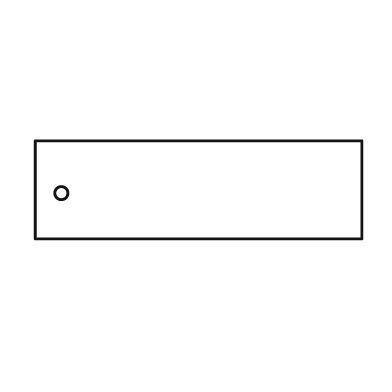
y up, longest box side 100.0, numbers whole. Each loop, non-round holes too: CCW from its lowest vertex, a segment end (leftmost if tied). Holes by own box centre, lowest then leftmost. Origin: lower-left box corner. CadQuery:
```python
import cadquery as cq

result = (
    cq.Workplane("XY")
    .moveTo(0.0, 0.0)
    .lineTo(100.0, 0.0)
    .lineTo(100.0, 30.0)
    .lineTo(0.0, 30.0)
    .close()
    .moveTo(8.0, 14.0)
    .circle(2.0)
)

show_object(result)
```